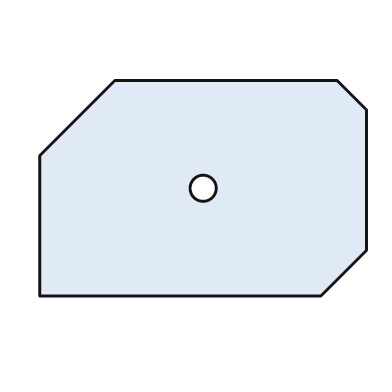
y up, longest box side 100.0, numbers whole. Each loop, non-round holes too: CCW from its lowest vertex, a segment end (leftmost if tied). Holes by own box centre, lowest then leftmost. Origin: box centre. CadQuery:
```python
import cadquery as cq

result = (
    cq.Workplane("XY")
    .moveTo(-50.0, -33.0)
    .lineTo(36.0, -33.0)
    .lineTo(50.0, -19.0)
    .lineTo(50.0, 24.0)
    .lineTo(41.0, 33.0)
    .lineTo(-27.0, 33.0)
    .lineTo(-50.0, 10.0)
    .close()
    .moveTo(0.0, 0.0)
    .circle(4.0)
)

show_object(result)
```